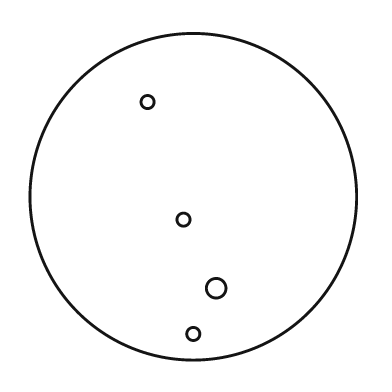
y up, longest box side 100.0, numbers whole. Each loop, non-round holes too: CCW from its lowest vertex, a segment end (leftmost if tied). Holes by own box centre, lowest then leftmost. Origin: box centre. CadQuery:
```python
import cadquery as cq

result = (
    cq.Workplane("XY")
    .moveTo(0.0, 0.0)
    .circle(50.0)
    .moveTo(0.0, -42.0)
    .circle(2.0)
    .moveTo(7.0, -28.0)
    .circle(3.0)
    .moveTo(-3.0, -7.0)
    .circle(2.0)
    .moveTo(-14.0, 29.0)
    .circle(2.0)
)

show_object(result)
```